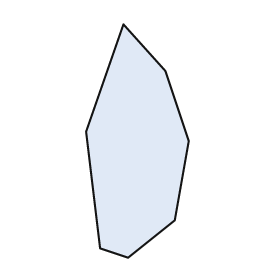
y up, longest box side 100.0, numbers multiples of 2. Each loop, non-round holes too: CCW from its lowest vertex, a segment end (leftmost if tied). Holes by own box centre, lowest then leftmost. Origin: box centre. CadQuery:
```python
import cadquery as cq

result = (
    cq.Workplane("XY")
    .moveTo(-4.0, -50.0)
    .lineTo(16.0, -34.0)
    .lineTo(22.0, 0.0)
    .lineTo(12.0, 30.0)
    .lineTo(-6.0, 50.0)
    .lineTo(-22.0, 4.0)
    .lineTo(-16.0, -46.0)
    .close()
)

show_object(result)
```